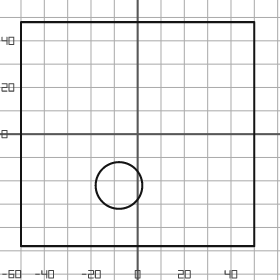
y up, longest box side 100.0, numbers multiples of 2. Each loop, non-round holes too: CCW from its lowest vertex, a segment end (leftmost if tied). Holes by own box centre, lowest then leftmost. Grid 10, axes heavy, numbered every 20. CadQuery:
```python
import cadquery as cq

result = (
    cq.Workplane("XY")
    .moveTo(-50.0, -48.0)
    .lineTo(50.0, -48.0)
    .lineTo(50.0, 48.0)
    .lineTo(-50.0, 48.0)
    .close()
    .moveTo(-8.0, -22.0)
    .circle(10.0)
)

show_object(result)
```